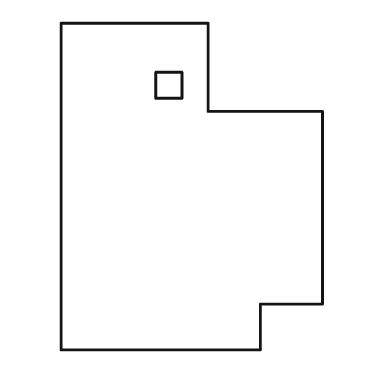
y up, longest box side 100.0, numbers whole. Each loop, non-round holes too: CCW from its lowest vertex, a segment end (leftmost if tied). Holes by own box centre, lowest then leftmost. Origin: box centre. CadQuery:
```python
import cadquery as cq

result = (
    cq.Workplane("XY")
    .moveTo(-40.0, -50.0)
    .lineTo(21.0, -50.0)
    .lineTo(21.0, -36.0)
    .lineTo(40.0, -36.0)
    .lineTo(40.0, 23.0)
    .lineTo(5.0, 23.0)
    .lineTo(5.0, 50.0)
    .lineTo(-40.0, 50.0)
    .close()
    .moveTo(-11.0, 27.0)
    .lineTo(-3.0, 27.0)
    .lineTo(-3.0, 35.0)
    .lineTo(-11.0, 35.0)
    .close()
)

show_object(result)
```